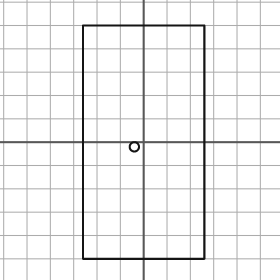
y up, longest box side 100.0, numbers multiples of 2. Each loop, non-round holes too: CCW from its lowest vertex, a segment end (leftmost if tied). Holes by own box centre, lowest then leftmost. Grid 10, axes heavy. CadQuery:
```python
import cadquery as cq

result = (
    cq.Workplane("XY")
    .moveTo(-26.0, -50.0)
    .lineTo(26.0, -50.0)
    .lineTo(26.0, 50.0)
    .lineTo(-26.0, 50.0)
    .close()
    .moveTo(-4.0, -2.0)
    .circle(2.0)
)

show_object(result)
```